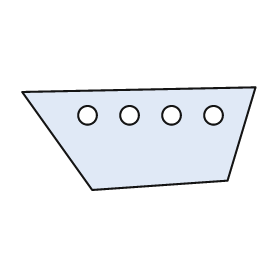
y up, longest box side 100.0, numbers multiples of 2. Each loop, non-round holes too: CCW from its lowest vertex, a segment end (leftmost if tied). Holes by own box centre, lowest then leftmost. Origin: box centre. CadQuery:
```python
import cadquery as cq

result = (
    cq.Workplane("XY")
    .moveTo(-20.0, -22.0)
    .lineTo(38.0, -18.0)
    .lineTo(50.0, 22.0)
    .lineTo(-50.0, 20.0)
    .close()
    .moveTo(-22.0, 10.0)
    .circle(4.0)
    .moveTo(-4.0, 10.0)
    .circle(4.0)
    .moveTo(14.0, 10.0)
    .circle(4.0)
    .moveTo(32.0, 10.0)
    .circle(4.0)
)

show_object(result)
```